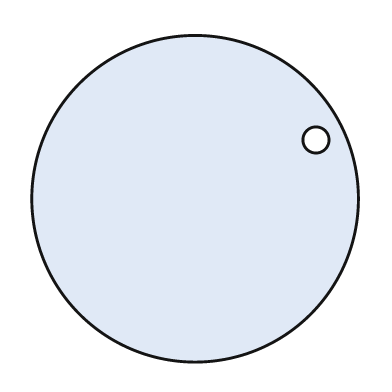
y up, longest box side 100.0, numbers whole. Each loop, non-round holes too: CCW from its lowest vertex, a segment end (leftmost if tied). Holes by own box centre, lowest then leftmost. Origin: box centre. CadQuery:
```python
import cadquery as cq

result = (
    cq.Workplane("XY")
    .moveTo(0.0, 0.0)
    .circle(50.0)
    .moveTo(37.0, 18.0)
    .circle(4.0)
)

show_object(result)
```